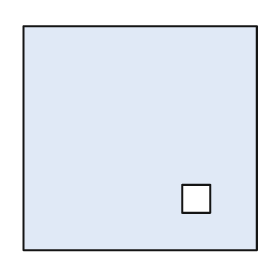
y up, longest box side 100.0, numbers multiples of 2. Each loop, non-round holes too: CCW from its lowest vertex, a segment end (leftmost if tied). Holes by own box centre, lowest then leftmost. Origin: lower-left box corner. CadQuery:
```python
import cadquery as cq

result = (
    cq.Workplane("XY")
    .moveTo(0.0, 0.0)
    .lineTo(100.0, 0.0)
    .lineTo(100.0, 96.0)
    .lineTo(0.0, 96.0)
    .close()
    .moveTo(68.0, 16.0)
    .lineTo(80.0, 16.0)
    .lineTo(80.0, 28.0)
    .lineTo(68.0, 28.0)
    .close()
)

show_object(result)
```